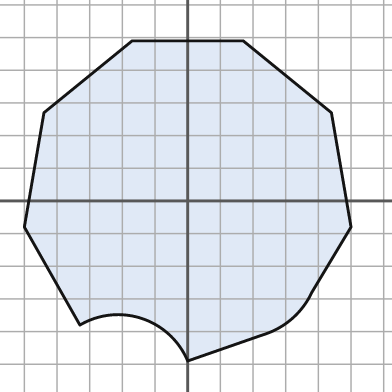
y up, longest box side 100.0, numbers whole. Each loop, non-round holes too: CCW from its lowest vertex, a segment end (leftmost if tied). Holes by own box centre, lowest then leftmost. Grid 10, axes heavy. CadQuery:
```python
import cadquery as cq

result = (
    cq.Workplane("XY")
    .moveTo(0.0, -49.0)
    .lineTo(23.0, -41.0)
    .threePointArc((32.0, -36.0), (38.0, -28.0))
    .lineTo(50.0, -8.0)
    .lineTo(44.0, 27.0)
    .lineTo(17.0, 49.0)
    .lineTo(-17.0, 49.0)
    .lineTo(-44.0, 27.0)
    .lineTo(-50.0, -8.0)
    .lineTo(-33.0, -38.0)
    .threePointArc((-14.0, -36.0), (0.0, -49.0))
    .close()
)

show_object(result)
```